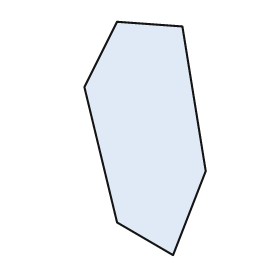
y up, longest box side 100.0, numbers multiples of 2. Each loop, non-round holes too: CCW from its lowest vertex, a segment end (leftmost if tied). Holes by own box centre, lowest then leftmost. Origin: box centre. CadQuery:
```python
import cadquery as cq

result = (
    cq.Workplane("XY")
    .moveTo(12.0, -50.0)
    .lineTo(26.0, -14.0)
    .lineTo(16.0, 48.0)
    .lineTo(-12.0, 50.0)
    .lineTo(-26.0, 22.0)
    .lineTo(-12.0, -36.0)
    .close()
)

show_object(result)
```